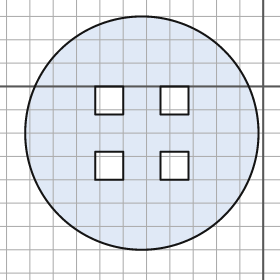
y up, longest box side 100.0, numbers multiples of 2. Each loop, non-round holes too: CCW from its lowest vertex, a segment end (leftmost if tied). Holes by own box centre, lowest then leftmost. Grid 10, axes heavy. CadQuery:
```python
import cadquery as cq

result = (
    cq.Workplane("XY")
    .moveTo(-52.0, -20.0)
    .circle(50.0)
    .moveTo(-72.0, -40.0)
    .lineTo(-60.0, -40.0)
    .lineTo(-60.0, -28.0)
    .lineTo(-72.0, -28.0)
    .close()
    .moveTo(-44.0, -40.0)
    .lineTo(-32.0, -40.0)
    .lineTo(-32.0, -28.0)
    .lineTo(-44.0, -28.0)
    .close()
    .moveTo(-72.0, -12.0)
    .lineTo(-60.0, -12.0)
    .lineTo(-60.0, 0.0)
    .lineTo(-72.0, 0.0)
    .close()
    .moveTo(-44.0, -12.0)
    .lineTo(-32.0, -12.0)
    .lineTo(-32.0, 0.0)
    .lineTo(-44.0, 0.0)
    .close()
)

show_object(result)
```